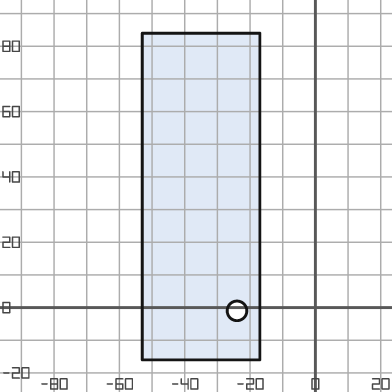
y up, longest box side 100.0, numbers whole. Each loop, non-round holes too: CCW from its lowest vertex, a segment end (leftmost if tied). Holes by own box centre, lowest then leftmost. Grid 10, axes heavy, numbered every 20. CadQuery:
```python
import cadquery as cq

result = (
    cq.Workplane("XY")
    .moveTo(-53.0, -16.0)
    .lineTo(-17.0, -16.0)
    .lineTo(-17.0, 84.0)
    .lineTo(-53.0, 84.0)
    .close()
    .moveTo(-24.0, -1.0)
    .circle(3.0)
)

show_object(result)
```